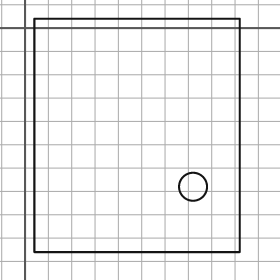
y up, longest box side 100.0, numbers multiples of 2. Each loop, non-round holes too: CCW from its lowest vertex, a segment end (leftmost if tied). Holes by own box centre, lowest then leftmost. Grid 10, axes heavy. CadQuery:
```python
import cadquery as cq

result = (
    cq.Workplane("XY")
    .moveTo(4.0, -96.0)
    .lineTo(92.0, -96.0)
    .lineTo(92.0, 4.0)
    .lineTo(4.0, 4.0)
    .close()
    .moveTo(72.0, -68.0)
    .circle(6.0)
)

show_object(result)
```